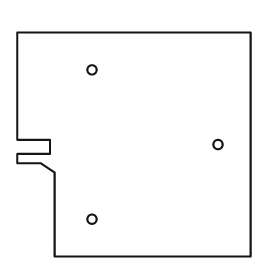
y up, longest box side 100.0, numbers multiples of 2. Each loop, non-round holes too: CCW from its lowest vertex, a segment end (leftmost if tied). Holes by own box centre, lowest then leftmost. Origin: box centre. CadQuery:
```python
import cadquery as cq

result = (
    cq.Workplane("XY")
    .moveTo(-34.0, -48.0)
    .lineTo(50.0, -48.0)
    .lineTo(50.0, 48.0)
    .lineTo(-50.0, 48.0)
    .lineTo(-50.0, 2.0)
    .lineTo(-36.0, 2.0)
    .lineTo(-36.0, -4.0)
    .lineTo(-50.0, -4.0)
    .lineTo(-50.0, -8.0)
    .lineTo(-40.0, -8.0)
    .lineTo(-34.0, -12.0)
    .close()
    .moveTo(-18.0, -32.0)
    .circle(2.0)
    .moveTo(36.0, 0.0)
    .circle(2.0)
    .moveTo(-18.0, 32.0)
    .circle(2.0)
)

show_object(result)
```